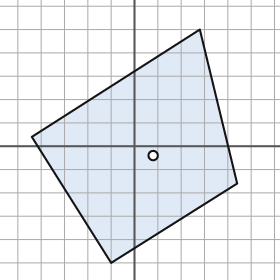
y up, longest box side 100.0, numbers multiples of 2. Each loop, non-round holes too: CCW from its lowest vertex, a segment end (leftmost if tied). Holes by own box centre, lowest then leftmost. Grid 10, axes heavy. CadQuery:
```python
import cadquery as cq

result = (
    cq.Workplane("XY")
    .moveTo(-10.0, -50.0)
    .lineTo(44.0, -16.0)
    .lineTo(28.0, 50.0)
    .lineTo(-44.0, 4.0)
    .close()
    .moveTo(8.0, -4.0)
    .circle(2.0)
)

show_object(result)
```